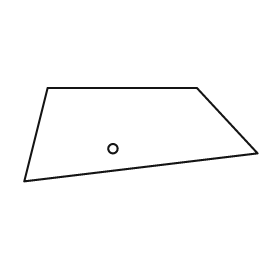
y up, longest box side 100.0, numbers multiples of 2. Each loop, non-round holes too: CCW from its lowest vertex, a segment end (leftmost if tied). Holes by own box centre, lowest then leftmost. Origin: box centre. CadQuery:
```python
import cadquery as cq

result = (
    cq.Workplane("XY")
    .moveTo(-50.0, -20.0)
    .lineTo(50.0, -8.0)
    .lineTo(24.0, 20.0)
    .lineTo(-40.0, 20.0)
    .close()
    .moveTo(-12.0, -6.0)
    .circle(2.0)
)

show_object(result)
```